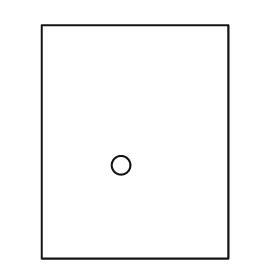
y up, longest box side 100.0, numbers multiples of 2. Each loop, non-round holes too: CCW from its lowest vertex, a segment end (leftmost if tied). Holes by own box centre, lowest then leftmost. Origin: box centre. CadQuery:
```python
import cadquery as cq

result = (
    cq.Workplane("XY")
    .moveTo(-40.0, -50.0)
    .lineTo(40.0, -50.0)
    .lineTo(40.0, 50.0)
    .lineTo(-40.0, 50.0)
    .close()
    .moveTo(-6.0, -10.0)
    .circle(4.0)
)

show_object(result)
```